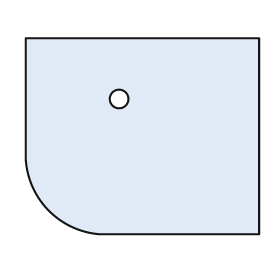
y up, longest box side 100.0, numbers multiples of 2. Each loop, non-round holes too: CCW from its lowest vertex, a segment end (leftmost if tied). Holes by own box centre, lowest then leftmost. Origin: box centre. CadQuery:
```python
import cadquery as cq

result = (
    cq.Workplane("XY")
    .moveTo(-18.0, -42.0)
    .lineTo(50.0, -42.0)
    .lineTo(50.0, 42.0)
    .lineTo(-50.0, 42.0)
    .lineTo(-50.0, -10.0)
    .threePointArc((-40.0, -32.0), (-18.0, -42.0))
    .close()
    .moveTo(-10.0, 16.0)
    .circle(4.0)
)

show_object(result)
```